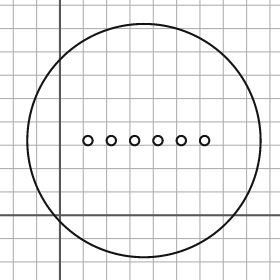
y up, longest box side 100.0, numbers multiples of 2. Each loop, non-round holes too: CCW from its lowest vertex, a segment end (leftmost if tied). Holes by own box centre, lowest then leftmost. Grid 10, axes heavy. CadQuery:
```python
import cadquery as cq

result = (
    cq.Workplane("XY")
    .moveTo(36.0, 32.0)
    .circle(50.0)
    .moveTo(12.0, 32.0)
    .circle(2.0)
    .moveTo(22.0, 32.0)
    .circle(2.0)
    .moveTo(32.0, 32.0)
    .circle(2.0)
    .moveTo(42.0, 32.0)
    .circle(2.0)
    .moveTo(52.0, 32.0)
    .circle(2.0)
    .moveTo(62.0, 32.0)
    .circle(2.0)
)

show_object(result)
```